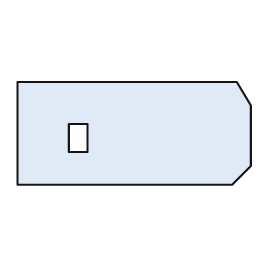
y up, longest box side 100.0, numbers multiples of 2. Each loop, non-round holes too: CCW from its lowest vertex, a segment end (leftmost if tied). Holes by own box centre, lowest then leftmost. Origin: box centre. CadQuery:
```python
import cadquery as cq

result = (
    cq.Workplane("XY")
    .moveTo(-50.0, -22.0)
    .lineTo(42.0, -22.0)
    .lineTo(50.0, -14.0)
    .lineTo(50.0, 12.0)
    .lineTo(44.0, 22.0)
    .lineTo(-50.0, 22.0)
    .close()
    .moveTo(-28.0, -8.0)
    .lineTo(-20.0, -8.0)
    .lineTo(-20.0, 4.0)
    .lineTo(-28.0, 4.0)
    .close()
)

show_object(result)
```